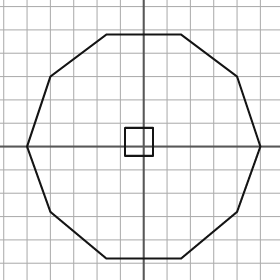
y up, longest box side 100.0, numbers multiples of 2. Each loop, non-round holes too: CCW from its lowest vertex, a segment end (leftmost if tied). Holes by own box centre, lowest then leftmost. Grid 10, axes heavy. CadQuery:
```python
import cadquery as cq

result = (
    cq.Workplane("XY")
    .moveTo(-16.0, -48.0)
    .lineTo(16.0, -48.0)
    .lineTo(40.0, -28.0)
    .lineTo(50.0, 0.0)
    .lineTo(40.0, 30.0)
    .lineTo(16.0, 48.0)
    .lineTo(-16.0, 48.0)
    .lineTo(-40.0, 30.0)
    .lineTo(-50.0, 0.0)
    .lineTo(-40.0, -28.0)
    .close()
    .moveTo(-8.0, -4.0)
    .lineTo(4.0, -4.0)
    .lineTo(4.0, 8.0)
    .lineTo(-8.0, 8.0)
    .close()
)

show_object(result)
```